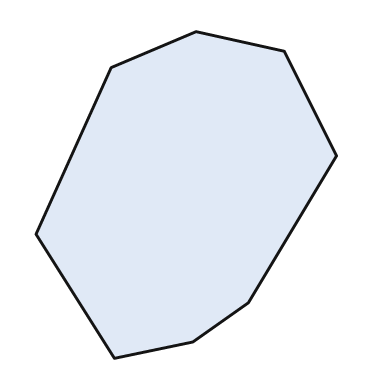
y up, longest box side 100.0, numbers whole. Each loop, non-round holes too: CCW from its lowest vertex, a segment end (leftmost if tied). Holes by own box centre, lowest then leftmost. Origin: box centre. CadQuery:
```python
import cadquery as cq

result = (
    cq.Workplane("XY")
    .moveTo(-22.0, -50.0)
    .lineTo(2.0, -45.0)
    .lineTo(19.0, -33.0)
    .lineTo(46.0, 12.0)
    .lineTo(30.0, 44.0)
    .lineTo(3.0, 50.0)
    .lineTo(-23.0, 39.0)
    .lineTo(-46.0, -12.0)
    .close()
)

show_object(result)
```